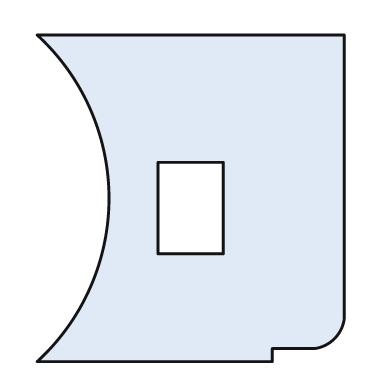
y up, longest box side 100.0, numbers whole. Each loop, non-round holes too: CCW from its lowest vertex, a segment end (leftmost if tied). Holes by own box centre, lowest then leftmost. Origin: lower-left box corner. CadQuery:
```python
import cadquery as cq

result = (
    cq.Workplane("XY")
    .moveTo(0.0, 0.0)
    .lineTo(72.0, 0.0)
    .lineTo(72.0, 4.0)
    .lineTo(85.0, 4.0)
    .threePointArc((91.0, 7.0), (94.0, 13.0))
    .lineTo(94.0, 100.0)
    .lineTo(0.0, 100.0)
    .threePointArc((22.0, 50.0), (0.0, 0.0))
    .close()
    .moveTo(37.0, 33.0)
    .lineTo(57.0, 33.0)
    .lineTo(57.0, 61.0)
    .lineTo(37.0, 61.0)
    .close()
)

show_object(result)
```